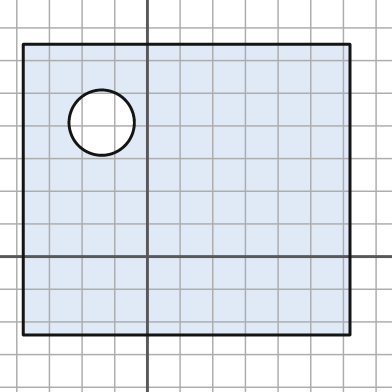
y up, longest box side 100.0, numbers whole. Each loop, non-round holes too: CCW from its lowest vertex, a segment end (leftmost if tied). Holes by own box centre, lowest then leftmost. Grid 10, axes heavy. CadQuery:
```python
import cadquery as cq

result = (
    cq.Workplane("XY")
    .moveTo(-38.0, -24.0)
    .lineTo(62.0, -24.0)
    .lineTo(62.0, 65.0)
    .lineTo(-38.0, 65.0)
    .close()
    .moveTo(-14.0, 41.0)
    .circle(10.0)
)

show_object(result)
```